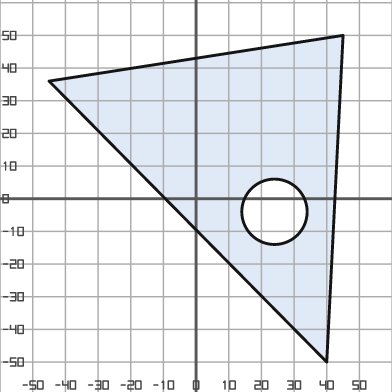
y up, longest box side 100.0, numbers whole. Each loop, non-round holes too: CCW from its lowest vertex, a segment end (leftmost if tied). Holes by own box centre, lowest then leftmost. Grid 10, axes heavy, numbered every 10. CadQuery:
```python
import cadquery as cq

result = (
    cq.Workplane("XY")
    .moveTo(40.0, -50.0)
    .lineTo(45.0, 50.0)
    .lineTo(-45.0, 36.0)
    .close()
    .moveTo(24.0, -4.0)
    .circle(10.0)
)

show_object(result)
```